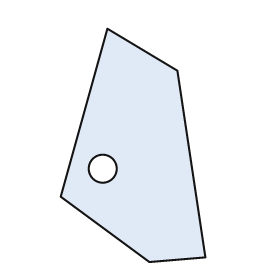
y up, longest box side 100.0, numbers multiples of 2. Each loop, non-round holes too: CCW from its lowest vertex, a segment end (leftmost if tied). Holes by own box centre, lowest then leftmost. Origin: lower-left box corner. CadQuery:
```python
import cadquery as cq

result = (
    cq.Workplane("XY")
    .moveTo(38.0, 0.0)
    .lineTo(62.0, 2.0)
    .lineTo(50.0, 82.0)
    .lineTo(20.0, 100.0)
    .lineTo(0.0, 28.0)
    .close()
    .moveTo(18.0, 40.0)
    .circle(6.0)
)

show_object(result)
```